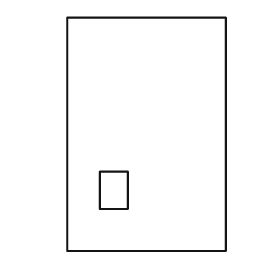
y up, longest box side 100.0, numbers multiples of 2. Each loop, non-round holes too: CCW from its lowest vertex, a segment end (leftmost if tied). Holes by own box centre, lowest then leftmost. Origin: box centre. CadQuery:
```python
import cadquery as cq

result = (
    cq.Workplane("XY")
    .moveTo(-34.0, -50.0)
    .lineTo(34.0, -50.0)
    .lineTo(34.0, 50.0)
    .lineTo(-34.0, 50.0)
    .close()
    .moveTo(-20.0, -32.0)
    .lineTo(-8.0, -32.0)
    .lineTo(-8.0, -16.0)
    .lineTo(-20.0, -16.0)
    .close()
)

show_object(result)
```